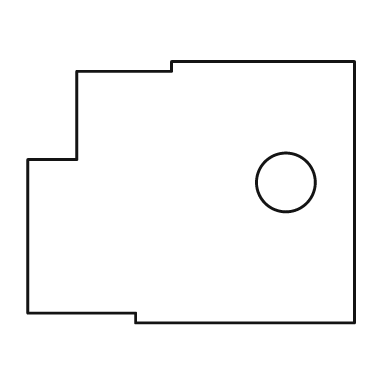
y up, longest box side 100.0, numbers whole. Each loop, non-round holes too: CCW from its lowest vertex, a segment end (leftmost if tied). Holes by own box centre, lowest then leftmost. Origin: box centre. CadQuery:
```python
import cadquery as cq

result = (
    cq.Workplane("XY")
    .moveTo(-17.0, -40.0)
    .lineTo(50.0, -40.0)
    .lineTo(50.0, 40.0)
    .lineTo(-6.0, 40.0)
    .lineTo(-6.0, 37.0)
    .lineTo(-35.0, 37.0)
    .lineTo(-35.0, 10.0)
    .lineTo(-50.0, 10.0)
    .lineTo(-50.0, -37.0)
    .lineTo(-17.0, -37.0)
    .close()
    .moveTo(29.0, 3.0)
    .circle(9.0)
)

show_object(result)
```